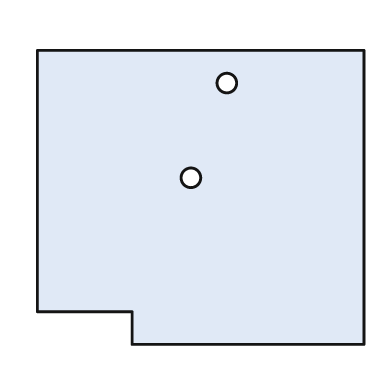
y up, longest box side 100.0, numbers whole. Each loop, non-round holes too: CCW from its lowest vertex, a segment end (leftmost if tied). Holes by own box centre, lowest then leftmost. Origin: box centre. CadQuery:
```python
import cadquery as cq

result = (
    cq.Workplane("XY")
    .moveTo(-21.0, -45.0)
    .lineTo(50.0, -45.0)
    .lineTo(50.0, 45.0)
    .lineTo(-50.0, 45.0)
    .lineTo(-50.0, -35.0)
    .lineTo(-21.0, -35.0)
    .close()
    .moveTo(-3.0, 6.0)
    .circle(3.0)
    .moveTo(8.0, 35.0)
    .circle(3.0)
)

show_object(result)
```